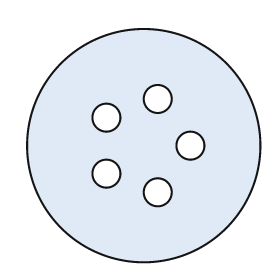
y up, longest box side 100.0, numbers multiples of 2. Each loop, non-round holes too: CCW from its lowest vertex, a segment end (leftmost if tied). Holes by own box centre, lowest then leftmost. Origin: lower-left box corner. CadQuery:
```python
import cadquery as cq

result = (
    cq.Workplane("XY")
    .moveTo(50.0, 50.0)
    .circle(50.0)
    .moveTo(56.0, 30.0)
    .circle(6.0)
    .moveTo(34.0, 38.0)
    .circle(6.0)
    .moveTo(70.0, 50.0)
    .circle(6.0)
    .moveTo(34.0, 62.0)
    .circle(6.0)
    .moveTo(56.0, 70.0)
    .circle(6.0)
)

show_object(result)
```